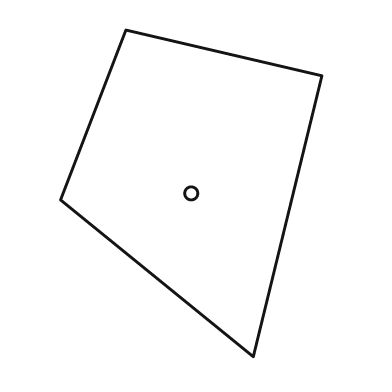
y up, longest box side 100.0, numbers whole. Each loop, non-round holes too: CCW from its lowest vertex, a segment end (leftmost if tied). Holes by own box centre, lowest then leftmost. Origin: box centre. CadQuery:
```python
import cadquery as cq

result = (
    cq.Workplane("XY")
    .moveTo(19.0, -50.0)
    .lineTo(40.0, 36.0)
    .lineTo(-20.0, 50.0)
    .lineTo(-40.0, -2.0)
    .close()
    .moveTo(0.0, 0.0)
    .circle(2.0)
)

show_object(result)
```